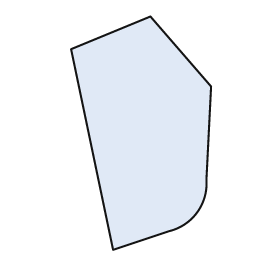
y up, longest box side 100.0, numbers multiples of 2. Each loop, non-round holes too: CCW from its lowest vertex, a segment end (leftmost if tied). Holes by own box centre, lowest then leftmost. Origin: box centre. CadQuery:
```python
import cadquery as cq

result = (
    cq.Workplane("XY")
    .moveTo(-12.0, -50.0)
    .lineTo(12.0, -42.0)
    .threePointArc((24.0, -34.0), (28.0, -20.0))
    .lineTo(30.0, 20.0)
    .lineTo(4.0, 50.0)
    .lineTo(-30.0, 36.0)
    .close()
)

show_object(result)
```